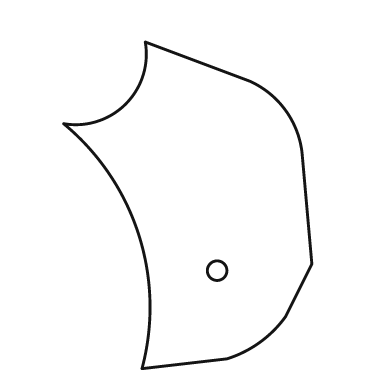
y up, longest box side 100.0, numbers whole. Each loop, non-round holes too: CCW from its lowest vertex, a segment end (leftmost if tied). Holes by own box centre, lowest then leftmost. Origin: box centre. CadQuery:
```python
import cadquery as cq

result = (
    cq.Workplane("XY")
    .moveTo(-14.0, -50.0)
    .lineTo(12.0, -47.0)
    .threePointArc((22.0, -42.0), (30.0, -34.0))
    .lineTo(38.0, -18.0)
    .lineTo(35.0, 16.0)
    .threePointArc((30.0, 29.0), (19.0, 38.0))
    .lineTo(-13.0, 50.0)
    .threePointArc((-19.0, 31.0), (-38.0, 25.0))
    .threePointArc((-15.0, -9.0), (-14.0, -50.0))
    .close()
    .moveTo(9.0, -20.0)
    .circle(3.0)
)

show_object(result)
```